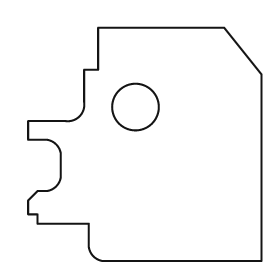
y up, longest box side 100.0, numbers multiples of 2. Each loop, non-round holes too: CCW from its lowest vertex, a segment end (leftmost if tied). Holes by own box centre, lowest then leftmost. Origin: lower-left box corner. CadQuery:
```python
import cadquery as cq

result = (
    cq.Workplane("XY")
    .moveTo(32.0, 0.0)
    .lineTo(100.0, 0.0)
    .lineTo(100.0, 80.0)
    .lineTo(84.0, 100.0)
    .lineTo(30.0, 100.0)
    .lineTo(30.0, 82.0)
    .lineTo(24.0, 82.0)
    .lineTo(24.0, 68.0)
    .threePointArc((22.0, 62.0), (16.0, 60.0))
    .lineTo(0.0, 60.0)
    .lineTo(0.0, 52.0)
    .lineTo(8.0, 52.0)
    .threePointArc((12.0, 50.0), (14.0, 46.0))
    .lineTo(14.0, 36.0)
    .threePointArc((12.0, 32.0), (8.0, 30.0))
    .lineTo(4.0, 30.0)
    .lineTo(0.0, 26.0)
    .lineTo(0.0, 20.0)
    .lineTo(4.0, 20.0)
    .lineTo(4.0, 16.0)
    .lineTo(26.0, 16.0)
    .lineTo(26.0, 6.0)
    .threePointArc((28.0, 2.0), (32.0, 0.0))
    .close()
    .moveTo(46.0, 66.0)
    .circle(10.0)
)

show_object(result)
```